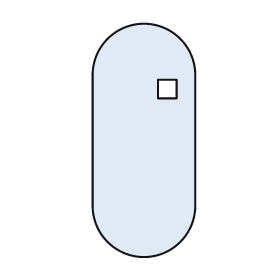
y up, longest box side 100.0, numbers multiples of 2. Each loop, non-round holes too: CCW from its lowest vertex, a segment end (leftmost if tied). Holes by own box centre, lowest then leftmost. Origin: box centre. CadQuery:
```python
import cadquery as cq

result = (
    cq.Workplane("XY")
    .moveTo(-22.0, -28.0)
    .threePointArc((0.0, -50.0), (22.0, -28.0))
    .lineTo(22.0, 28.0)
    .threePointArc((0.0, 50.0), (-22.0, 28.0))
    .close()
    .moveTo(6.0, 18.0)
    .lineTo(14.0, 18.0)
    .lineTo(14.0, 26.0)
    .lineTo(6.0, 26.0)
    .close()
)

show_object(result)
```